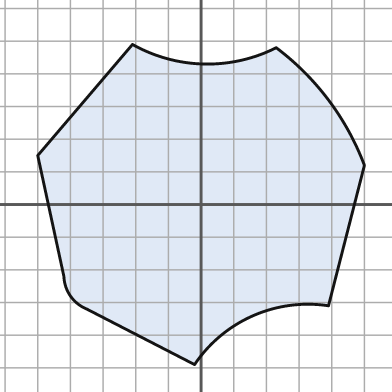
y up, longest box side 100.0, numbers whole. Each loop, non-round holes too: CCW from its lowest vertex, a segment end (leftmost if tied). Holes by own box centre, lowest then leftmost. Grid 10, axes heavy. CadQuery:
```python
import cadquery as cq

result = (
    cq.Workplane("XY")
    .moveTo(-2.0, -49.0)
    .threePointArc((16.0, -34.0), (39.0, -31.0))
    .lineTo(50.0, 12.0)
    .threePointArc((39.0, 32.0), (23.0, 48.0))
    .threePointArc((1.0, 43.0), (-21.0, 49.0))
    .lineTo(-50.0, 15.0)
    .lineTo(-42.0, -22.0)
    .threePointArc((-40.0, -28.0), (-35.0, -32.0))
    .close()
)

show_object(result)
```